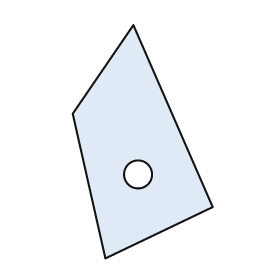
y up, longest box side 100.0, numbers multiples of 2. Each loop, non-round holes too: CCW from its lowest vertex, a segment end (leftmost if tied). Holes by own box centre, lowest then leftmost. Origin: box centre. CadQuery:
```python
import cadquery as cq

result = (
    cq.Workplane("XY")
    .moveTo(-16.0, -50.0)
    .lineTo(30.0, -28.0)
    .lineTo(-4.0, 50.0)
    .lineTo(-30.0, 12.0)
    .close()
    .moveTo(-2.0, -14.0)
    .circle(6.0)
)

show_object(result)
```